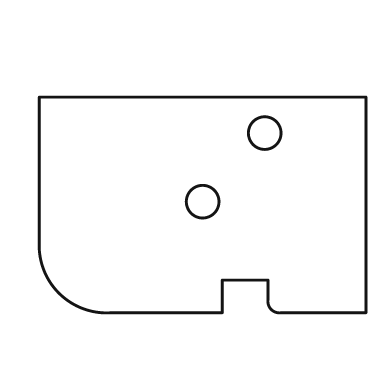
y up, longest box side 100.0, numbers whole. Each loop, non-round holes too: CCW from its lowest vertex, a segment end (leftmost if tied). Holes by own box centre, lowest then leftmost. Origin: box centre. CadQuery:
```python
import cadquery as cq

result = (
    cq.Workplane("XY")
    .moveTo(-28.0, -33.0)
    .lineTo(6.0, -33.0)
    .lineTo(6.0, -23.0)
    .lineTo(20.0, -23.0)
    .lineTo(20.0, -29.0)
    .threePointArc((21.0, -32.0), (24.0, -33.0))
    .lineTo(50.0, -33.0)
    .lineTo(50.0, 33.0)
    .lineTo(-50.0, 33.0)
    .lineTo(-50.0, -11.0)
    .threePointArc((-44.0, -27.0), (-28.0, -33.0))
    .close()
    .moveTo(0.0, 1.0)
    .circle(5.0)
    .moveTo(19.0, 22.0)
    .circle(5.0)
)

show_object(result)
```